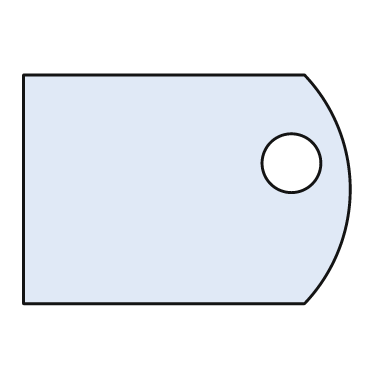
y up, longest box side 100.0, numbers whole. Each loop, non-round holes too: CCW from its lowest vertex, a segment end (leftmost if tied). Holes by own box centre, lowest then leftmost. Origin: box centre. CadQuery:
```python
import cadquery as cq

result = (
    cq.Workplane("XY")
    .moveTo(-50.0, -35.0)
    .lineTo(36.0, -35.0)
    .threePointArc((50.0, 0.0), (36.0, 35.0))
    .lineTo(-50.0, 35.0)
    .close()
    .moveTo(32.0, 8.0)
    .circle(9.0)
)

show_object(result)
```